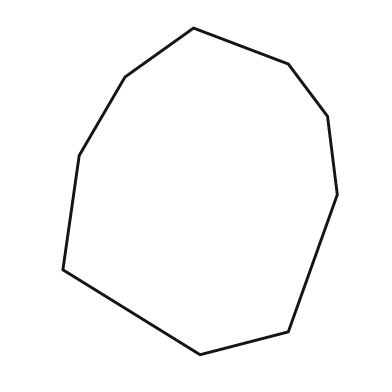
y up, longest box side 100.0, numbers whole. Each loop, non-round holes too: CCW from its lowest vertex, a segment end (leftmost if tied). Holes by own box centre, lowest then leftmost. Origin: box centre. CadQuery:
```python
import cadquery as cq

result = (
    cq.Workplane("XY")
    .moveTo(0.0, -50.0)
    .lineTo(27.0, -43.0)
    .lineTo(42.0, -1.0)
    .lineTo(39.0, 23.0)
    .lineTo(27.0, 39.0)
    .lineTo(-2.0, 50.0)
    .lineTo(-23.0, 35.0)
    .lineTo(-37.0, 11.0)
    .lineTo(-42.0, -24.0)
    .close()
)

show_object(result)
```